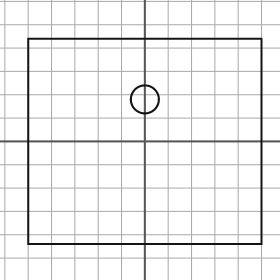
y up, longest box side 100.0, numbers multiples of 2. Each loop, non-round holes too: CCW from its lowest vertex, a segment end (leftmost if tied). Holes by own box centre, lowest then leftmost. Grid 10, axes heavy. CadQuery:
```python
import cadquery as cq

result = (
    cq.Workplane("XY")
    .moveTo(-50.0, -44.0)
    .lineTo(50.0, -44.0)
    .lineTo(50.0, 44.0)
    .lineTo(-50.0, 44.0)
    .close()
    .moveTo(0.0, 18.0)
    .circle(6.0)
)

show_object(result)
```